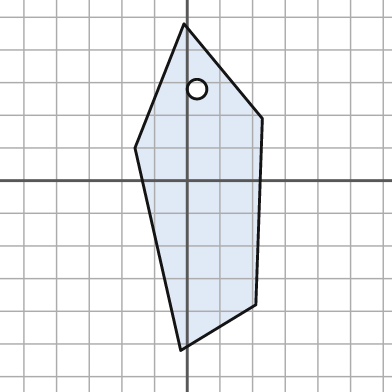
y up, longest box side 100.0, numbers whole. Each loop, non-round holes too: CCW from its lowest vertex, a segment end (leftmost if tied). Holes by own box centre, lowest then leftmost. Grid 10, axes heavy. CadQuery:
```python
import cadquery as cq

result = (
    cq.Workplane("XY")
    .moveTo(-2.0, -52.0)
    .lineTo(21.0, -38.0)
    .lineTo(23.0, 19.0)
    .lineTo(-1.0, 48.0)
    .lineTo(-16.0, 10.0)
    .close()
    .moveTo(3.0, 28.0)
    .circle(3.0)
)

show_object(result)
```